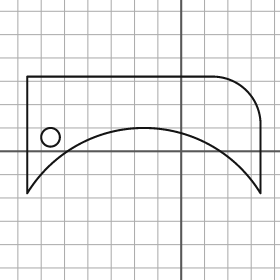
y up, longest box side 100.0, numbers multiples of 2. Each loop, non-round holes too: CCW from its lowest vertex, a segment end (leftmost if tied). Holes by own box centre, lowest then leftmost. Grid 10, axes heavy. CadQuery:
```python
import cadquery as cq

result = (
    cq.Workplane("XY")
    .moveTo(-66.0, -18.0)
    .threePointArc((-16.0, 10.0), (34.0, -18.0))
    .lineTo(34.0, 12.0)
    .threePointArc((28.0, 26.0), (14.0, 32.0))
    .lineTo(-66.0, 32.0)
    .close()
    .moveTo(-56.0, 6.0)
    .circle(4.0)
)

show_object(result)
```